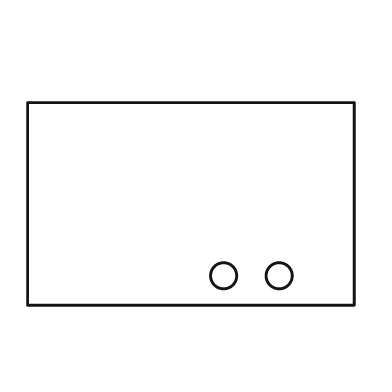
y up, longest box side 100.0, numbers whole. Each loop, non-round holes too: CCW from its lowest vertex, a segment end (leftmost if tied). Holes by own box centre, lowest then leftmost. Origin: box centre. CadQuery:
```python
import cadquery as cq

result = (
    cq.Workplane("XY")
    .moveTo(-50.0, -31.0)
    .lineTo(50.0, -31.0)
    .lineTo(50.0, 31.0)
    .lineTo(-50.0, 31.0)
    .close()
    .moveTo(10.0, -22.0)
    .circle(4.0)
    .moveTo(27.0, -22.0)
    .circle(4.0)
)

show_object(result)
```